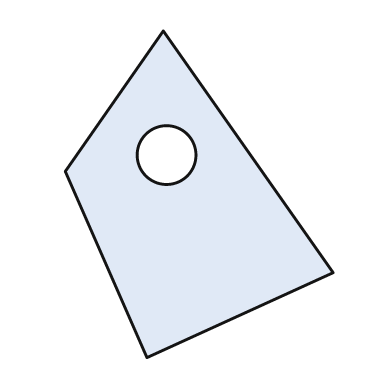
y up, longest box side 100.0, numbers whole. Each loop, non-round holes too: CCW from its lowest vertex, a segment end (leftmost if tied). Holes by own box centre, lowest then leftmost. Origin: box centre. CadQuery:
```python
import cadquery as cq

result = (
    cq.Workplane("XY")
    .moveTo(-16.0, -50.0)
    .lineTo(41.0, -24.0)
    .lineTo(-11.0, 50.0)
    .lineTo(-41.0, 7.0)
    .close()
    .moveTo(-10.0, 12.0)
    .circle(9.0)
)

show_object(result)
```